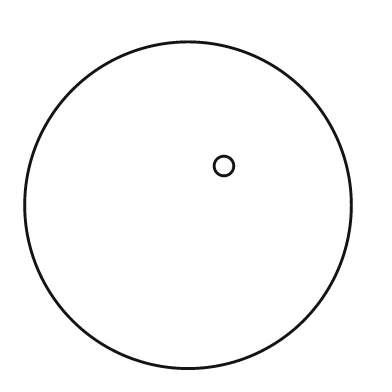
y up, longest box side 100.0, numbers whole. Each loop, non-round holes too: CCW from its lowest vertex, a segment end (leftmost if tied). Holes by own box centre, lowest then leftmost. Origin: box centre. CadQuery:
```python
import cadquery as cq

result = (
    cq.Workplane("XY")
    .moveTo(0.0, 0.0)
    .circle(50.0)
    .moveTo(11.0, 12.0)
    .circle(3.0)
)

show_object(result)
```